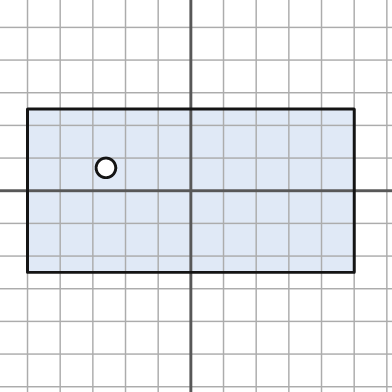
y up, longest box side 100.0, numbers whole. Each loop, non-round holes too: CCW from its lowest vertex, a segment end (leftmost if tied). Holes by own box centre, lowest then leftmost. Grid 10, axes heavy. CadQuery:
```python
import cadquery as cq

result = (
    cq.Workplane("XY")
    .moveTo(-50.0, -25.0)
    .lineTo(50.0, -25.0)
    .lineTo(50.0, 25.0)
    .lineTo(-50.0, 25.0)
    .close()
    .moveTo(-26.0, 7.0)
    .circle(3.0)
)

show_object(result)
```